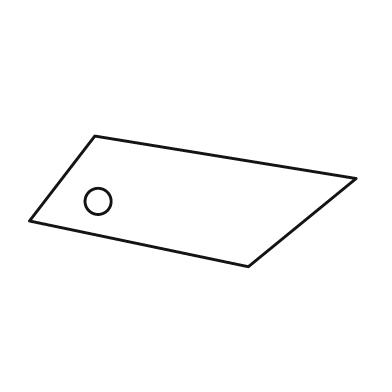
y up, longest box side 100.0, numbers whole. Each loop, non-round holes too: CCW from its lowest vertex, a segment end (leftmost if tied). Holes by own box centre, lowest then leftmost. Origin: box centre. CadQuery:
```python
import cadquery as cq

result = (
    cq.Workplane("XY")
    .moveTo(17.0, -20.0)
    .lineTo(50.0, 7.0)
    .lineTo(-30.0, 20.0)
    .lineTo(-50.0, -6.0)
    .close()
    .moveTo(-29.0, 0.0)
    .circle(4.0)
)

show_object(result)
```